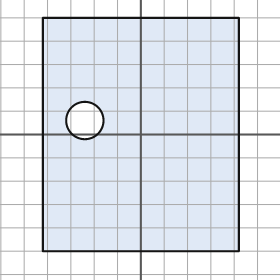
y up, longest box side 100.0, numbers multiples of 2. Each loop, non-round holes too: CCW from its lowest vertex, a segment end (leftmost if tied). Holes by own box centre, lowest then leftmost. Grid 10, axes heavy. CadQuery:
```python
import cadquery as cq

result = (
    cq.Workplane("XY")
    .moveTo(-42.0, -50.0)
    .lineTo(42.0, -50.0)
    .lineTo(42.0, 50.0)
    .lineTo(-42.0, 50.0)
    .close()
    .moveTo(-24.0, 6.0)
    .circle(8.0)
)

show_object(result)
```